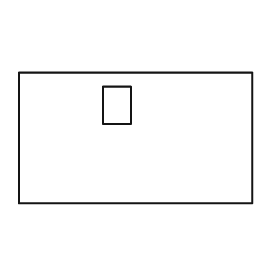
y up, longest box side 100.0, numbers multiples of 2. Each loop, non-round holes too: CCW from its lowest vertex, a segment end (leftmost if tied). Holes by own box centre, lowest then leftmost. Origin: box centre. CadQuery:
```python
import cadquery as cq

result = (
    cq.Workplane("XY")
    .moveTo(-50.0, -28.0)
    .lineTo(50.0, -28.0)
    .lineTo(50.0, 28.0)
    .lineTo(-50.0, 28.0)
    .close()
    .moveTo(-14.0, 6.0)
    .lineTo(-2.0, 6.0)
    .lineTo(-2.0, 22.0)
    .lineTo(-14.0, 22.0)
    .close()
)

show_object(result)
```